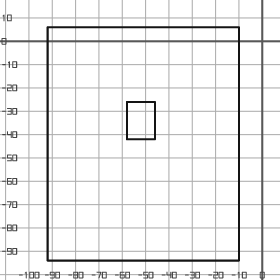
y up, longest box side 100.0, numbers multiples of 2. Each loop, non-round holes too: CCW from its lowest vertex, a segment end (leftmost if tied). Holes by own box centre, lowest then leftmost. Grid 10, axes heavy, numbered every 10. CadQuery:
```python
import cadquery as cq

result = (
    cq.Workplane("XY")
    .moveTo(-92.0, -94.0)
    .lineTo(-10.0, -94.0)
    .lineTo(-10.0, 6.0)
    .lineTo(-92.0, 6.0)
    .close()
    .moveTo(-58.0, -42.0)
    .lineTo(-46.0, -42.0)
    .lineTo(-46.0, -26.0)
    .lineTo(-58.0, -26.0)
    .close()
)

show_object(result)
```